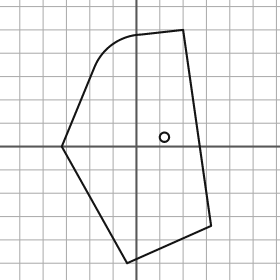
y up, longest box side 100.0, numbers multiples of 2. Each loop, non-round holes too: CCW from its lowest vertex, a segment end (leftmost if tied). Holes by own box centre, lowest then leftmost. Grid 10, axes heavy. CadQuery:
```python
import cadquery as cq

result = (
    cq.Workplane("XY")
    .moveTo(-4.0, -50.0)
    .lineTo(32.0, -34.0)
    .lineTo(20.0, 50.0)
    .lineTo(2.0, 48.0)
    .threePointArc((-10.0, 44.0), (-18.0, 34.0))
    .lineTo(-32.0, 0.0)
    .close()
    .moveTo(12.0, 4.0)
    .circle(2.0)
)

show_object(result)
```